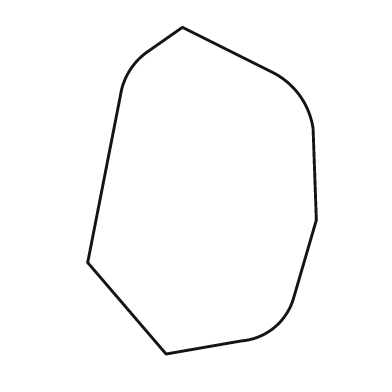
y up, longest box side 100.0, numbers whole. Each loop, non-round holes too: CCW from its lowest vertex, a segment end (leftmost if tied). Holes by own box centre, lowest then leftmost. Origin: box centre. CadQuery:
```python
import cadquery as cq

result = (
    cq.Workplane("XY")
    .moveTo(-11.0, -50.0)
    .lineTo(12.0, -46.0)
    .threePointArc((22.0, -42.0), (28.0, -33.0))
    .lineTo(35.0, -9.0)
    .lineTo(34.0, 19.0)
    .threePointArc((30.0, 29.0), (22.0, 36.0))
    .lineTo(-6.0, 50.0)
    .lineTo(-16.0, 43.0)
    .threePointArc((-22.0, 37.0), (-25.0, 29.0))
    .lineTo(-35.0, -22.0)
    .close()
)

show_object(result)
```